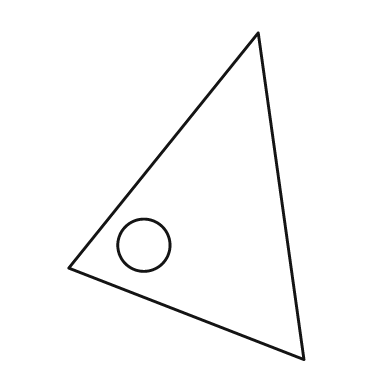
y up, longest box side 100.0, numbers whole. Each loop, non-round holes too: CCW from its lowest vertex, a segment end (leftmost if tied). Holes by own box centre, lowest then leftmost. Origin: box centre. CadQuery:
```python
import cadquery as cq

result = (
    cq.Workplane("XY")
    .moveTo(36.0, -50.0)
    .lineTo(22.0, 50.0)
    .lineTo(-36.0, -22.0)
    .close()
    .moveTo(-13.0, -15.0)
    .circle(8.0)
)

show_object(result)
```